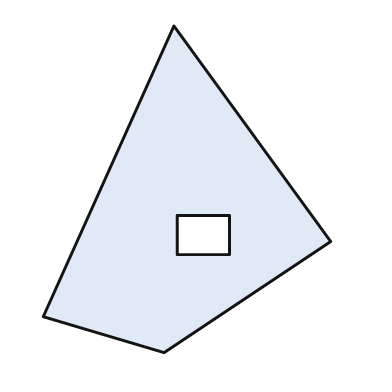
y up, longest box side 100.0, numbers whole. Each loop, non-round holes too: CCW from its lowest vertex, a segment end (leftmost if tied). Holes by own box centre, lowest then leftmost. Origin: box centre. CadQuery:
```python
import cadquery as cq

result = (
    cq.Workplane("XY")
    .moveTo(-7.0, -50.0)
    .lineTo(44.0, -16.0)
    .lineTo(-4.0, 50.0)
    .lineTo(-44.0, -39.0)
    .close()
    .moveTo(-3.0, -20.0)
    .lineTo(13.0, -20.0)
    .lineTo(13.0, -8.0)
    .lineTo(-3.0, -8.0)
    .close()
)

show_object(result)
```